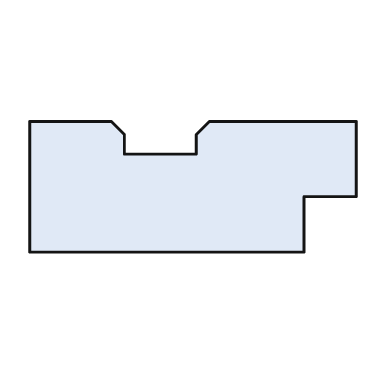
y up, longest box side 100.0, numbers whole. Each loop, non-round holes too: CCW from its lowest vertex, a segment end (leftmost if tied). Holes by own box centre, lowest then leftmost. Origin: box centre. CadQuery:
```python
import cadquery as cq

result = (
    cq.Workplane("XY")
    .moveTo(-50.0, -20.0)
    .lineTo(34.0, -20.0)
    .lineTo(34.0, -3.0)
    .lineTo(50.0, -3.0)
    .lineTo(50.0, 20.0)
    .lineTo(5.0, 20.0)
    .lineTo(1.0, 16.0)
    .lineTo(1.0, 10.0)
    .lineTo(-21.0, 10.0)
    .lineTo(-21.0, 16.0)
    .lineTo(-25.0, 20.0)
    .lineTo(-50.0, 20.0)
    .close()
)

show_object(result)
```